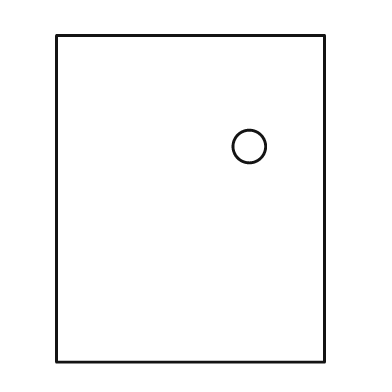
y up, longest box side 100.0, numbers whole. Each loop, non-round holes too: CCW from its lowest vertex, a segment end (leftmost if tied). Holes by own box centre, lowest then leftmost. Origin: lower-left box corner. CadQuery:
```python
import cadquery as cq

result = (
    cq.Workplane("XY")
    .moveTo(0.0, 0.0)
    .lineTo(82.0, 0.0)
    .lineTo(82.0, 100.0)
    .lineTo(0.0, 100.0)
    .close()
    .moveTo(59.0, 66.0)
    .circle(5.0)
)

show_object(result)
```